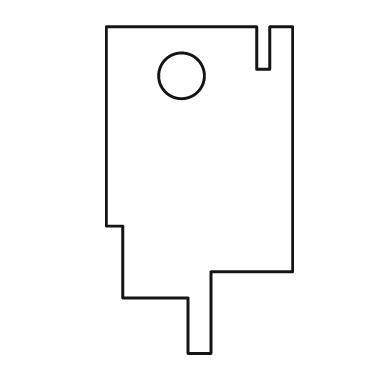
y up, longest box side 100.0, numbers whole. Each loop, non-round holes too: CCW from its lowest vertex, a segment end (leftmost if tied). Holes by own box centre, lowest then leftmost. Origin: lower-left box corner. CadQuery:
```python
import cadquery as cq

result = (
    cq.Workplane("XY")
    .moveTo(25.0, 0.0)
    .lineTo(32.0, 0.0)
    .lineTo(32.0, 25.0)
    .lineTo(57.0, 25.0)
    .lineTo(57.0, 100.0)
    .lineTo(50.0, 100.0)
    .lineTo(50.0, 87.0)
    .lineTo(46.0, 87.0)
    .lineTo(46.0, 100.0)
    .lineTo(0.0, 100.0)
    .lineTo(0.0, 39.0)
    .lineTo(5.0, 39.0)
    .lineTo(5.0, 17.0)
    .lineTo(25.0, 17.0)
    .close()
    .moveTo(23.0, 85.0)
    .circle(7.0)
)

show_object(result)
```